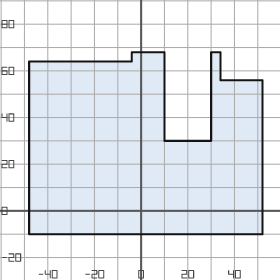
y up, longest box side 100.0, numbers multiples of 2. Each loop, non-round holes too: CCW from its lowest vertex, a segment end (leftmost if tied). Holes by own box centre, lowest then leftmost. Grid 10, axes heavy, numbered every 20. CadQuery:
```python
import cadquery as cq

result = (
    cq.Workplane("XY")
    .moveTo(-48.0, -10.0)
    .lineTo(52.0, -10.0)
    .lineTo(52.0, 56.0)
    .lineTo(34.0, 56.0)
    .lineTo(34.0, 68.0)
    .lineTo(30.0, 68.0)
    .lineTo(30.0, 30.0)
    .lineTo(10.0, 30.0)
    .lineTo(10.0, 68.0)
    .lineTo(-4.0, 68.0)
    .lineTo(-4.0, 64.0)
    .lineTo(-48.0, 64.0)
    .close()
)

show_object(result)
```